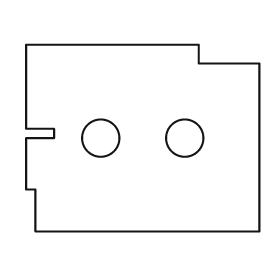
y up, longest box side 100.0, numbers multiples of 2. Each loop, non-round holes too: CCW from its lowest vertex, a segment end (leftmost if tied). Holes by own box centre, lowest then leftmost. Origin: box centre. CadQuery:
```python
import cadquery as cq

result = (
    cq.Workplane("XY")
    .moveTo(-46.0, -40.0)
    .lineTo(50.0, -40.0)
    .lineTo(50.0, 32.0)
    .lineTo(24.0, 32.0)
    .lineTo(24.0, 40.0)
    .lineTo(-50.0, 40.0)
    .lineTo(-50.0, 4.0)
    .lineTo(-38.0, 4.0)
    .lineTo(-38.0, 0.0)
    .lineTo(-50.0, 0.0)
    .lineTo(-50.0, -22.0)
    .lineTo(-46.0, -22.0)
    .close()
    .moveTo(-18.0, 0.0)
    .circle(8.0)
    .moveTo(18.0, 0.0)
    .circle(8.0)
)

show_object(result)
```